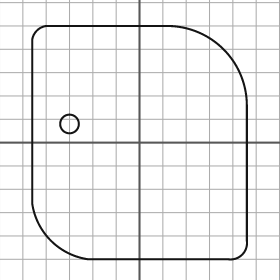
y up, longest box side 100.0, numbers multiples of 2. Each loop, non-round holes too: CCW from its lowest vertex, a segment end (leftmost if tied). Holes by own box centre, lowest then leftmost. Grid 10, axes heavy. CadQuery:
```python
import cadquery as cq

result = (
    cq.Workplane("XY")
    .moveTo(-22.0, -50.0)
    .lineTo(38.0, -50.0)
    .threePointArc((44.0, -48.0), (46.0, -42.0))
    .lineTo(46.0, 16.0)
    .threePointArc((36.0, 40.0), (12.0, 50.0))
    .lineTo(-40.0, 50.0)
    .threePointArc((-44.0, 48.0), (-46.0, 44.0))
    .lineTo(-46.0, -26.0)
    .threePointArc((-38.0, -42.0), (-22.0, -50.0))
    .close()
    .moveTo(-30.0, 8.0)
    .circle(4.0)
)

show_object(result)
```